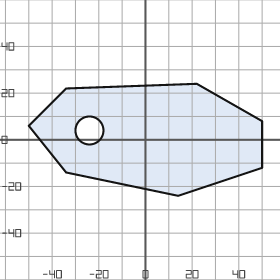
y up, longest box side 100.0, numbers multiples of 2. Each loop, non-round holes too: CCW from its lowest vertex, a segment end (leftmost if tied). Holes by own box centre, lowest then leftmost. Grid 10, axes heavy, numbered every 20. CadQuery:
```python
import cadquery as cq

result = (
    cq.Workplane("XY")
    .moveTo(14.0, -24.0)
    .lineTo(50.0, -12.0)
    .lineTo(50.0, 8.0)
    .lineTo(22.0, 24.0)
    .lineTo(-34.0, 22.0)
    .lineTo(-50.0, 6.0)
    .lineTo(-34.0, -14.0)
    .close()
    .moveTo(-24.0, 4.0)
    .circle(6.0)
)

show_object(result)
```